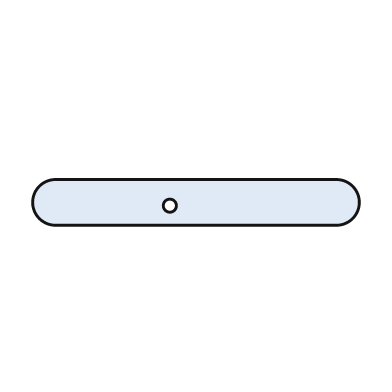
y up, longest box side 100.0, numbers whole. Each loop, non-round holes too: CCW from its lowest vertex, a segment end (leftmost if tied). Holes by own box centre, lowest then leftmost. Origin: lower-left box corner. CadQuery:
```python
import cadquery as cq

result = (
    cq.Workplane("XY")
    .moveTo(7.0, 0.0)
    .lineTo(93.0, 0.0)
    .threePointArc((100.0, 7.0), (93.0, 14.0))
    .lineTo(7.0, 14.0)
    .threePointArc((0.0, 7.0), (7.0, 0.0))
    .close()
    .moveTo(42.0, 6.0)
    .circle(2.0)
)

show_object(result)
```